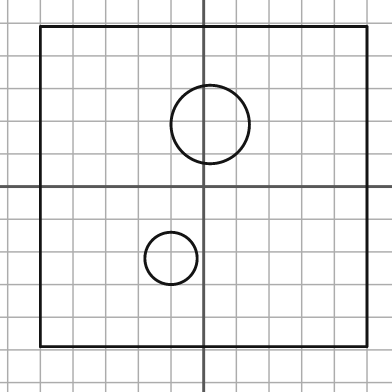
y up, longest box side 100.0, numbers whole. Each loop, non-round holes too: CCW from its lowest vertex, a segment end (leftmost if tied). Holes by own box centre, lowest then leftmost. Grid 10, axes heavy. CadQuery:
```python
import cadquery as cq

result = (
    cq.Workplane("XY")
    .moveTo(-50.0, -49.0)
    .lineTo(50.0, -49.0)
    .lineTo(50.0, 49.0)
    .lineTo(-50.0, 49.0)
    .close()
    .moveTo(-10.0, -22.0)
    .circle(8.0)
    .moveTo(2.0, 19.0)
    .circle(12.0)
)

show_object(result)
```